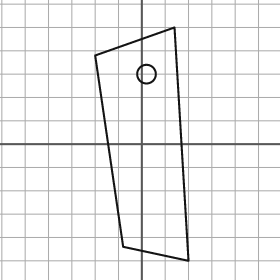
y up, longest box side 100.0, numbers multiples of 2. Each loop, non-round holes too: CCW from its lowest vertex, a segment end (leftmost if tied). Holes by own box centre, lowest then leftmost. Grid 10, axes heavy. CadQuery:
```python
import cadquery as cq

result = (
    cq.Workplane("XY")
    .moveTo(20.0, -50.0)
    .lineTo(14.0, 50.0)
    .lineTo(-20.0, 38.0)
    .lineTo(-8.0, -44.0)
    .close()
    .moveTo(2.0, 30.0)
    .circle(4.0)
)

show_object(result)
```